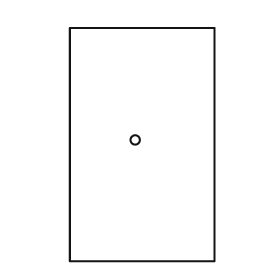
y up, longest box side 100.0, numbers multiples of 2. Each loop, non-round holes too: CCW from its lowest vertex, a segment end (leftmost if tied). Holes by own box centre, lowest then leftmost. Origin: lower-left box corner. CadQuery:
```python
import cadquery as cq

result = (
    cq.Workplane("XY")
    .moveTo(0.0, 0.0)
    .lineTo(62.0, 0.0)
    .lineTo(62.0, 100.0)
    .lineTo(0.0, 100.0)
    .close()
    .moveTo(28.0, 52.0)
    .circle(2.0)
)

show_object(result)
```